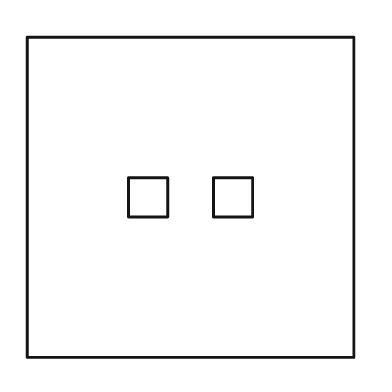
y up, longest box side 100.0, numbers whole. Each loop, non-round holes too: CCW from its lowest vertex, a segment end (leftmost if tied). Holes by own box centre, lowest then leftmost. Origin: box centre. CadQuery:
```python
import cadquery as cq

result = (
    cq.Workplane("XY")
    .moveTo(-50.0, -49.0)
    .lineTo(50.0, -49.0)
    .lineTo(50.0, 49.0)
    .lineTo(-50.0, 49.0)
    .close()
    .moveTo(-19.0, -6.0)
    .lineTo(-7.0, -6.0)
    .lineTo(-7.0, 6.0)
    .lineTo(-19.0, 6.0)
    .close()
    .moveTo(7.0, -6.0)
    .lineTo(19.0, -6.0)
    .lineTo(19.0, 6.0)
    .lineTo(7.0, 6.0)
    .close()
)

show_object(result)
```